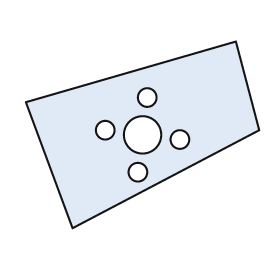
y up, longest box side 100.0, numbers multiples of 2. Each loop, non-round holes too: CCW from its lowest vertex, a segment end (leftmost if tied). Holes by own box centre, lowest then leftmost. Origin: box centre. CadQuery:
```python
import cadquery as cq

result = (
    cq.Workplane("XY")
    .moveTo(-30.0, -40.0)
    .lineTo(50.0, 2.0)
    .lineTo(40.0, 40.0)
    .lineTo(-50.0, 14.0)
    .close()
    .moveTo(-2.0, -16.0)
    .circle(4.0)
    .moveTo(16.0, -2.0)
    .circle(4.0)
    .moveTo(0.0, 0.0)
    .circle(8.0)
    .moveTo(-16.0, 2.0)
    .circle(4.0)
    .moveTo(2.0, 16.0)
    .circle(4.0)
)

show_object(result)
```